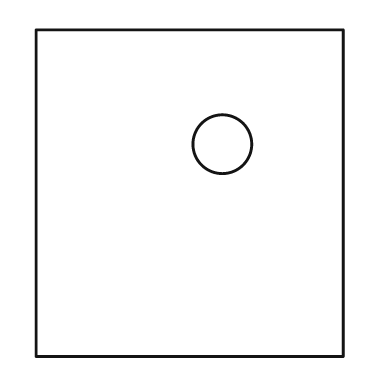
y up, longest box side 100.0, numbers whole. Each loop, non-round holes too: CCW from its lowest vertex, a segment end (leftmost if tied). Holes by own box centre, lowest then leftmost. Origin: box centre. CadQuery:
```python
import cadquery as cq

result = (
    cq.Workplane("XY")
    .moveTo(-47.0, -50.0)
    .lineTo(47.0, -50.0)
    .lineTo(47.0, 50.0)
    .lineTo(-47.0, 50.0)
    .close()
    .moveTo(10.0, 15.0)
    .circle(9.0)
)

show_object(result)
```